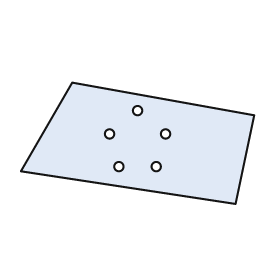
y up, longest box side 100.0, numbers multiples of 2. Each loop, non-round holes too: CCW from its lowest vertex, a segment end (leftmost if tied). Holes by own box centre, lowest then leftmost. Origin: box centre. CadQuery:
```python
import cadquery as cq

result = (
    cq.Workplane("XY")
    .moveTo(42.0, -26.0)
    .lineTo(50.0, 12.0)
    .lineTo(-28.0, 26.0)
    .lineTo(-50.0, -12.0)
    .close()
    .moveTo(-8.0, -10.0)
    .circle(2.0)
    .moveTo(8.0, -10.0)
    .circle(2.0)
    .moveTo(-12.0, 4.0)
    .circle(2.0)
    .moveTo(12.0, 4.0)
    .circle(2.0)
    .moveTo(0.0, 14.0)
    .circle(2.0)
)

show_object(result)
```